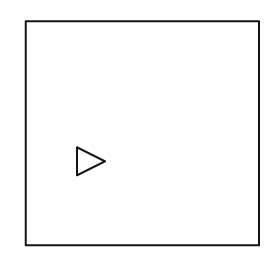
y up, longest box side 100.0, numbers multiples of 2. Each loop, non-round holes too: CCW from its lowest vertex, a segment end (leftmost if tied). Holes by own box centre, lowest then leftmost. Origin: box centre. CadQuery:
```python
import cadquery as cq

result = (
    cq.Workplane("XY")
    .moveTo(-50.0, -48.0)
    .lineTo(50.0, -48.0)
    .lineTo(50.0, 48.0)
    .lineTo(-50.0, 48.0)
    .close()
    .moveTo(-28.0, -18.0)
    .lineTo(-16.0, -12.0)
    .lineTo(-28.0, -6.0)
    .close()
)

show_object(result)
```